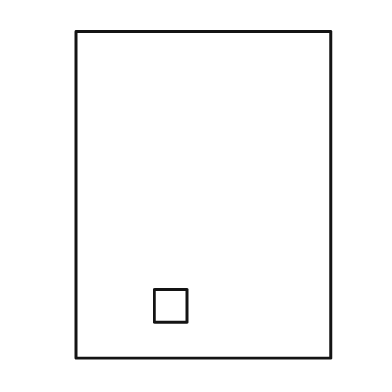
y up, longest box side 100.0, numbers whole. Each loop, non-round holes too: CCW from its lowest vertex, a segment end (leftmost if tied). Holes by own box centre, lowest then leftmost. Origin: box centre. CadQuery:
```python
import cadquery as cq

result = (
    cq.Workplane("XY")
    .moveTo(-39.0, -50.0)
    .lineTo(39.0, -50.0)
    .lineTo(39.0, 50.0)
    .lineTo(-39.0, 50.0)
    .close()
    .moveTo(-15.0, -39.0)
    .lineTo(-5.0, -39.0)
    .lineTo(-5.0, -29.0)
    .lineTo(-15.0, -29.0)
    .close()
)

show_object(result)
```